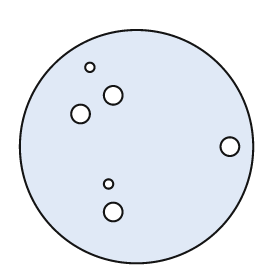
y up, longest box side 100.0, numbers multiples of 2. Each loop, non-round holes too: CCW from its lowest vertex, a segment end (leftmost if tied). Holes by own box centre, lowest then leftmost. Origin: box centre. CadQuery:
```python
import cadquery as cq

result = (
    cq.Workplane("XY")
    .moveTo(0.0, 0.0)
    .circle(50.0)
    .moveTo(-10.0, -28.0)
    .circle(4.0)
    .moveTo(-12.0, -16.0)
    .circle(2.0)
    .moveTo(40.0, 0.0)
    .circle(4.0)
    .moveTo(-24.0, 14.0)
    .circle(4.0)
    .moveTo(-10.0, 22.0)
    .circle(4.0)
    .moveTo(-20.0, 34.0)
    .circle(2.0)
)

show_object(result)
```